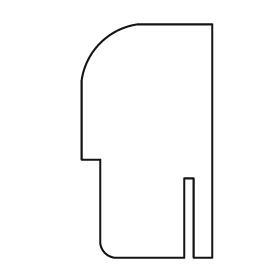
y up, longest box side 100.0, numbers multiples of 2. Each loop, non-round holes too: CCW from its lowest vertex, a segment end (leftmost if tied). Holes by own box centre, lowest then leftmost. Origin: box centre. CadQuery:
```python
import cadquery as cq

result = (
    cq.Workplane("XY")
    .moveTo(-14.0, -50.0)
    .lineTo(16.0, -50.0)
    .lineTo(16.0, -16.0)
    .lineTo(20.0, -16.0)
    .lineTo(20.0, -50.0)
    .lineTo(28.0, -50.0)
    .lineTo(28.0, 50.0)
    .lineTo(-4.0, 50.0)
    .threePointArc((-20.0, 42.0), (-28.0, 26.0))
    .lineTo(-28.0, -8.0)
    .lineTo(-20.0, -8.0)
    .lineTo(-20.0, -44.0)
    .threePointArc((-18.0, -48.0), (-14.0, -50.0))
    .close()
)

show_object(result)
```